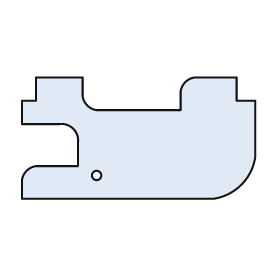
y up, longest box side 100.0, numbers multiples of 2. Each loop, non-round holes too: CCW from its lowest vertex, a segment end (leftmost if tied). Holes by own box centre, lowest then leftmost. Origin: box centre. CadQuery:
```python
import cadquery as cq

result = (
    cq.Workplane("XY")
    .moveTo(-50.0, -26.0)
    .lineTo(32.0, -26.0)
    .threePointArc((44.0, -20.0), (50.0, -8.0))
    .lineTo(50.0, 16.0)
    .lineTo(42.0, 16.0)
    .lineTo(42.0, 26.0)
    .lineTo(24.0, 26.0)
    .threePointArc((20.0, 24.0), (18.0, 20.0))
    .lineTo(18.0, 12.0)
    .lineTo(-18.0, 12.0)
    .threePointArc((-22.0, 14.0), (-24.0, 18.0))
    .lineTo(-24.0, 26.0)
    .lineTo(-44.0, 26.0)
    .lineTo(-44.0, 16.0)
    .lineTo(-50.0, 16.0)
    .lineTo(-50.0, 6.0)
    .lineTo(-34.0, 6.0)
    .threePointArc((-28.0, 4.0), (-26.0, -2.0))
    .lineTo(-26.0, -12.0)
    .lineTo(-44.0, -12.0)
    .threePointArc((-48.0, -14.0), (-50.0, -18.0))
    .close()
    .moveTo(-18.0, -16.0)
    .circle(2.0)
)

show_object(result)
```